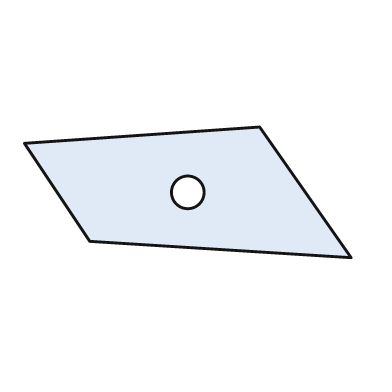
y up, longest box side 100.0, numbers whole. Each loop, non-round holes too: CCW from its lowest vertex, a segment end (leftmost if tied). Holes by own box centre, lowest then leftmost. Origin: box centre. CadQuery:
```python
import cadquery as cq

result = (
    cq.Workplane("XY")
    .moveTo(50.0, -20.0)
    .lineTo(22.0, 20.0)
    .lineTo(-50.0, 15.0)
    .lineTo(-30.0, -15.0)
    .close()
    .moveTo(0.0, 0.0)
    .circle(5.0)
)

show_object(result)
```